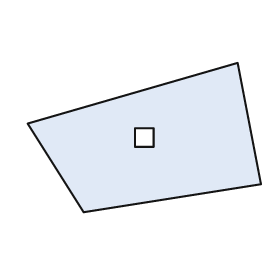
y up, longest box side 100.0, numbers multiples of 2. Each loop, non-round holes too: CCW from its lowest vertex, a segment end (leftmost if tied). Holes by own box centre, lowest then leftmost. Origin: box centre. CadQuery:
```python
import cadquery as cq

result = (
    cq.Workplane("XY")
    .moveTo(-26.0, -32.0)
    .lineTo(50.0, -20.0)
    .lineTo(40.0, 32.0)
    .lineTo(-50.0, 6.0)
    .close()
    .moveTo(-4.0, -4.0)
    .lineTo(4.0, -4.0)
    .lineTo(4.0, 4.0)
    .lineTo(-4.0, 4.0)
    .close()
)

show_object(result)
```